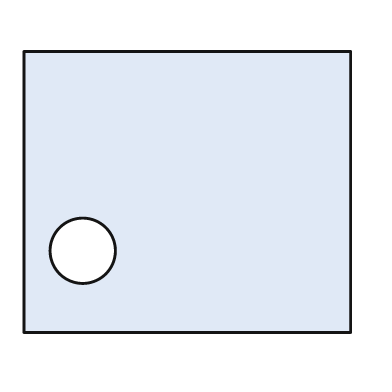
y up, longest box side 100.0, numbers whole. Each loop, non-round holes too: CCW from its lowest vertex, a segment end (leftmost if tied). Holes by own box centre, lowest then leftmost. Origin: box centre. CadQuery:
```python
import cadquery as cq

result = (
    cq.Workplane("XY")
    .moveTo(-50.0, -43.0)
    .lineTo(50.0, -43.0)
    .lineTo(50.0, 43.0)
    .lineTo(-50.0, 43.0)
    .close()
    .moveTo(-32.0, -18.0)
    .circle(10.0)
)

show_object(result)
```